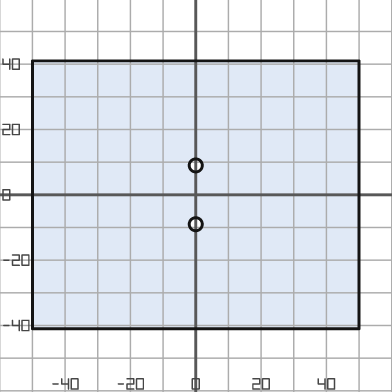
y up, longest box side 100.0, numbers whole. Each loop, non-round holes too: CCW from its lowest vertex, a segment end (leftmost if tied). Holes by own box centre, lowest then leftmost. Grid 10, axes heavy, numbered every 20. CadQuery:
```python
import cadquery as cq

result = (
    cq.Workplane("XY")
    .moveTo(-50.0, -41.0)
    .lineTo(50.0, -41.0)
    .lineTo(50.0, 41.0)
    .lineTo(-50.0, 41.0)
    .close()
    .moveTo(0.0, -9.0)
    .circle(2.0)
    .moveTo(0.0, 9.0)
    .circle(2.0)
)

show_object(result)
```